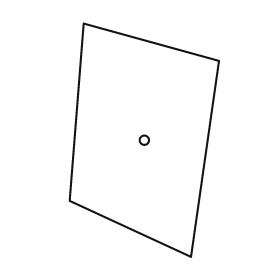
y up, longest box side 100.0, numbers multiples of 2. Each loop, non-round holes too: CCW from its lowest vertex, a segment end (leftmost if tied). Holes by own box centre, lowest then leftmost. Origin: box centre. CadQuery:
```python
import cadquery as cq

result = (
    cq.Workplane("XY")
    .moveTo(20.0, -50.0)
    .lineTo(32.0, 34.0)
    .lineTo(-26.0, 50.0)
    .lineTo(-32.0, -26.0)
    .close()
    .moveTo(0.0, 0.0)
    .circle(2.0)
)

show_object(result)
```